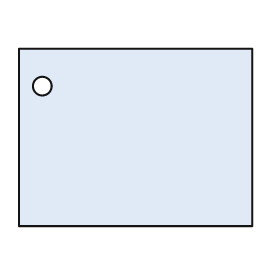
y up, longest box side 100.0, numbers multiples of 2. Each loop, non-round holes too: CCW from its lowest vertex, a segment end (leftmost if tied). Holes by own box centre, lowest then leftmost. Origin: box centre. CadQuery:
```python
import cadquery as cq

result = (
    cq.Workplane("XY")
    .moveTo(-50.0, -38.0)
    .lineTo(50.0, -38.0)
    .lineTo(50.0, 38.0)
    .lineTo(-50.0, 38.0)
    .close()
    .moveTo(-40.0, 22.0)
    .circle(4.0)
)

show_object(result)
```